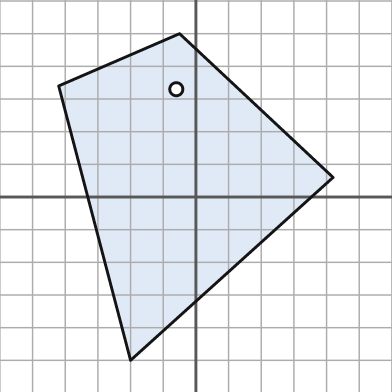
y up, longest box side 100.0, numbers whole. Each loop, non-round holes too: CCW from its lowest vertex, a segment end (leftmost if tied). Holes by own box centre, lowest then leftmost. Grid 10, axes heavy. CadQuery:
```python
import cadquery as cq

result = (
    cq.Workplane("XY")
    .moveTo(-20.0, -50.0)
    .lineTo(42.0, 6.0)
    .lineTo(-5.0, 50.0)
    .lineTo(-42.0, 34.0)
    .close()
    .moveTo(-6.0, 33.0)
    .circle(2.0)
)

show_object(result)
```